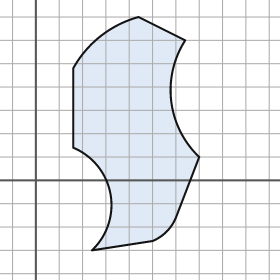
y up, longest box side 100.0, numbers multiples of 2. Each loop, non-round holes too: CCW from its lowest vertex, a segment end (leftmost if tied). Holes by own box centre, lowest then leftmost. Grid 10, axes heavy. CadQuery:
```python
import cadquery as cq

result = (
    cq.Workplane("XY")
    .moveTo(24.0, -30.0)
    .lineTo(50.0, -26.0)
    .threePointArc((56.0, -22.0), (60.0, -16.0))
    .lineTo(70.0, 10.0)
    .threePointArc((58.0, 34.0), (64.0, 60.0))
    .lineTo(44.0, 70.0)
    .threePointArc((28.0, 62.0), (16.0, 48.0))
    .lineTo(16.0, 14.0)
    .threePointArc((32.0, -6.0), (24.0, -30.0))
    .close()
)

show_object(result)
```